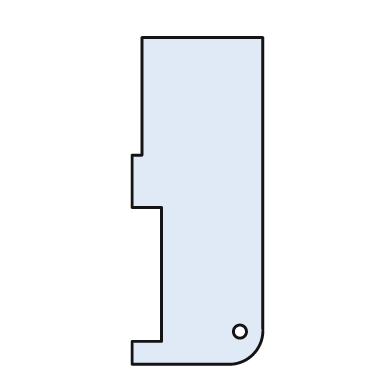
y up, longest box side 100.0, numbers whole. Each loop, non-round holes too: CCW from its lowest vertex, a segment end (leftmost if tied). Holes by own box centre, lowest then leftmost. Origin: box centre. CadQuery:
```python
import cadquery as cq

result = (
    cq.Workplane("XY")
    .moveTo(-20.0, -50.0)
    .lineTo(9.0, -50.0)
    .threePointArc((17.0, -47.0), (20.0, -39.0))
    .lineTo(20.0, 50.0)
    .lineTo(-17.0, 50.0)
    .lineTo(-17.0, 14.0)
    .lineTo(-20.0, 14.0)
    .lineTo(-20.0, -2.0)
    .lineTo(-11.0, -2.0)
    .lineTo(-11.0, -43.0)
    .lineTo(-20.0, -43.0)
    .close()
    .moveTo(13.0, -40.0)
    .circle(2.0)
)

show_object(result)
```